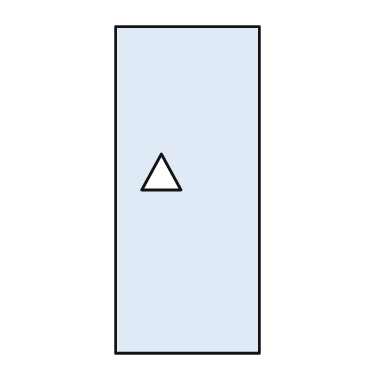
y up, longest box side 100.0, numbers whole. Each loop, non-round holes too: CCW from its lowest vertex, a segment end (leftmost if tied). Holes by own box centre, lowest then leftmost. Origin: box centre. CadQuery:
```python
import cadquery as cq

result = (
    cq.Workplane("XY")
    .moveTo(-22.0, -50.0)
    .lineTo(22.0, -50.0)
    .lineTo(22.0, 50.0)
    .lineTo(-22.0, 50.0)
    .close()
    .moveTo(-14.0, 0.0)
    .lineTo(-2.0, 0.0)
    .lineTo(-8.0, 11.0)
    .close()
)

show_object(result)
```